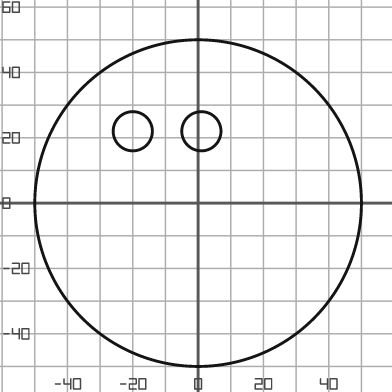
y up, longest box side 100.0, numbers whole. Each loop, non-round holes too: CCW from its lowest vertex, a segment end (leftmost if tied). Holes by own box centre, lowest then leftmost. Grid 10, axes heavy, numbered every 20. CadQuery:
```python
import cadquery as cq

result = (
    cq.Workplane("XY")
    .moveTo(0.0, 0.0)
    .circle(50.0)
    .moveTo(-20.0, 22.0)
    .circle(6.0)
    .moveTo(1.0, 22.0)
    .circle(6.0)
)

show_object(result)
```